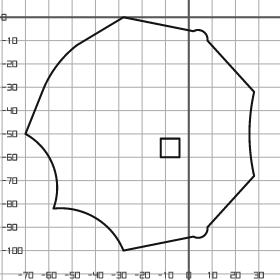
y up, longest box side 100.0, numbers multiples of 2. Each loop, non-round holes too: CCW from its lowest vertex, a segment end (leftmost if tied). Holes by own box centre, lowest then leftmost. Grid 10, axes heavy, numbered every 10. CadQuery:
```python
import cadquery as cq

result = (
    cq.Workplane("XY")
    .moveTo(-28.0, -100.0)
    .lineTo(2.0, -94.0)
    .threePointArc((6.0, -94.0), (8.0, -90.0))
    .lineTo(28.0, -68.0)
    .threePointArc((26.0, -50.0), (28.0, -32.0))
    .lineTo(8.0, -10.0)
    .threePointArc((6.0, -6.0), (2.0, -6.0))
    .lineTo(-28.0, 0.0)
    .lineTo(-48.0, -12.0)
    .threePointArc((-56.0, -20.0), (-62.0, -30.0))
    .lineTo(-70.0, -50.0)
    .threePointArc((-58.0, -64.0), (-58.0, -82.0))
    .threePointArc((-40.0, -86.0), (-28.0, -100.0))
    .close()
    .moveTo(-12.0, -60.0)
    .lineTo(-4.0, -60.0)
    .lineTo(-4.0, -52.0)
    .lineTo(-12.0, -52.0)
    .close()
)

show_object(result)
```